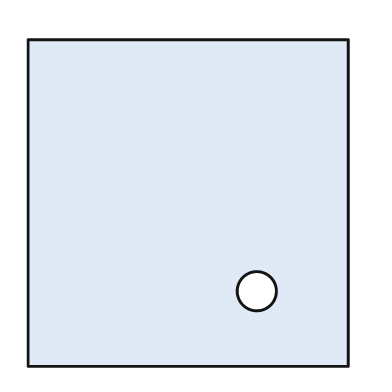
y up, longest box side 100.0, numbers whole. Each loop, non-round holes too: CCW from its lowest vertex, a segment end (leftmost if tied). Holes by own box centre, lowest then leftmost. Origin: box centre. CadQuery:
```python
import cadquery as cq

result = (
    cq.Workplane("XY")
    .moveTo(-49.0, -50.0)
    .lineTo(49.0, -50.0)
    .lineTo(49.0, 50.0)
    .lineTo(-49.0, 50.0)
    .close()
    .moveTo(21.0, -27.0)
    .circle(6.0)
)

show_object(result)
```